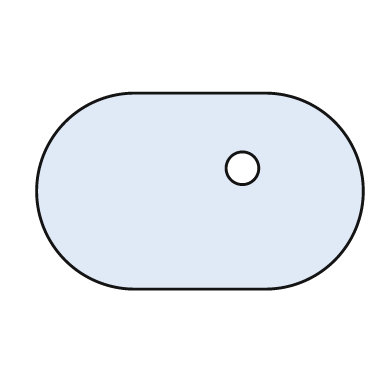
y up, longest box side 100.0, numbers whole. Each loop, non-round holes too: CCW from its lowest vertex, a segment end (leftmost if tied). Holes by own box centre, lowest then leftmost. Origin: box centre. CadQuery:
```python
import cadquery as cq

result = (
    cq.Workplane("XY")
    .moveTo(-20.0, -30.0)
    .lineTo(20.0, -30.0)
    .threePointArc((50.0, 0.0), (20.0, 30.0))
    .lineTo(-20.0, 30.0)
    .threePointArc((-50.0, 0.0), (-20.0, -30.0))
    .close()
    .moveTo(13.0, 7.0)
    .circle(5.0)
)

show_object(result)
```